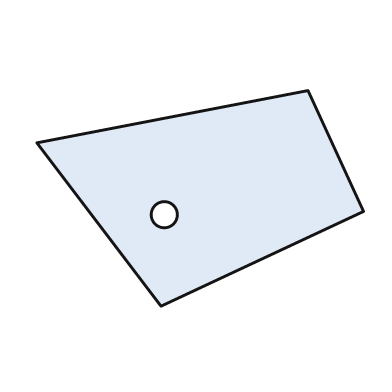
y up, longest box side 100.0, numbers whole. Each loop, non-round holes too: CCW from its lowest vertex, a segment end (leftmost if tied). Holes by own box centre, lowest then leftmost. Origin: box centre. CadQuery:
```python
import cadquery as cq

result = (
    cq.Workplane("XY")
    .moveTo(-12.0, -33.0)
    .lineTo(50.0, -4.0)
    .lineTo(33.0, 33.0)
    .lineTo(-50.0, 17.0)
    .close()
    .moveTo(-11.0, -5.0)
    .circle(4.0)
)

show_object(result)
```